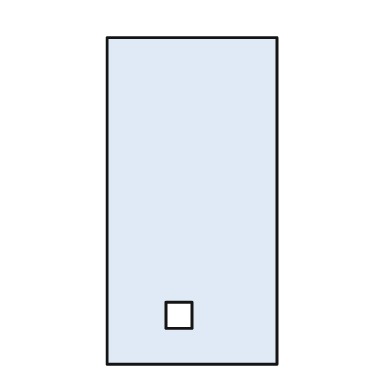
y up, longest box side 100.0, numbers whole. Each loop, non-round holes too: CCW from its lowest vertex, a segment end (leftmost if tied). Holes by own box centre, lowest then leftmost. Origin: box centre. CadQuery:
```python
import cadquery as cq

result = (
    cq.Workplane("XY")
    .moveTo(-26.0, -50.0)
    .lineTo(26.0, -50.0)
    .lineTo(26.0, 50.0)
    .lineTo(-26.0, 50.0)
    .close()
    .moveTo(-8.0, -39.0)
    .lineTo(0.0, -39.0)
    .lineTo(0.0, -31.0)
    .lineTo(-8.0, -31.0)
    .close()
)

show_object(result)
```